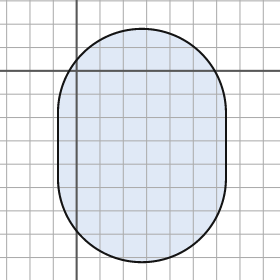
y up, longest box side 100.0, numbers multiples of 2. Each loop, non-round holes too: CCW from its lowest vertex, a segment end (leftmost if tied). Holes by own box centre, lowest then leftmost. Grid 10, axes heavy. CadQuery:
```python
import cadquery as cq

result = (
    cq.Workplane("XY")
    .moveTo(-8.0, -46.0)
    .threePointArc((28.0, -82.0), (64.0, -46.0))
    .lineTo(64.0, -18.0)
    .threePointArc((28.0, 18.0), (-8.0, -18.0))
    .close()
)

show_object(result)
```